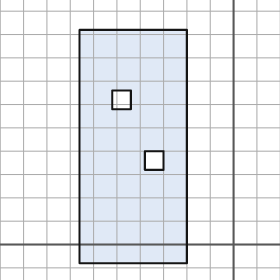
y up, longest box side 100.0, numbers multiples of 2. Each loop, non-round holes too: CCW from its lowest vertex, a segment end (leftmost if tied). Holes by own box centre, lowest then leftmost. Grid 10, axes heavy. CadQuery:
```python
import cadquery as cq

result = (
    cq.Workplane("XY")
    .moveTo(-66.0, -8.0)
    .lineTo(-20.0, -8.0)
    .lineTo(-20.0, 92.0)
    .lineTo(-66.0, 92.0)
    .close()
    .moveTo(-38.0, 32.0)
    .lineTo(-30.0, 32.0)
    .lineTo(-30.0, 40.0)
    .lineTo(-38.0, 40.0)
    .close()
    .moveTo(-52.0, 58.0)
    .lineTo(-44.0, 58.0)
    .lineTo(-44.0, 66.0)
    .lineTo(-52.0, 66.0)
    .close()
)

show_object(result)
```